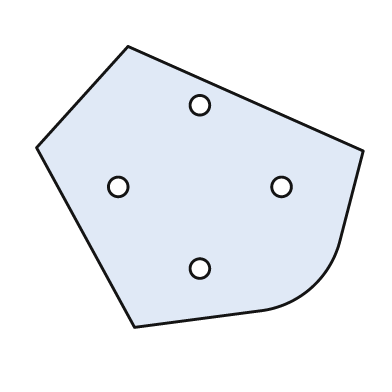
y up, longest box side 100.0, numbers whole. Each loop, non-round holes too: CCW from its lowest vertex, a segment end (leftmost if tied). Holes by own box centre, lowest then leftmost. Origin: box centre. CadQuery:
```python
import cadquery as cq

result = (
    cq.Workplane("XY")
    .moveTo(-20.0, -43.0)
    .lineTo(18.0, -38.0)
    .threePointArc((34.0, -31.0), (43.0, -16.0))
    .lineTo(50.0, 11.0)
    .lineTo(-22.0, 43.0)
    .lineTo(-50.0, 12.0)
    .close()
    .moveTo(0.0, -25.0)
    .circle(3.0)
    .moveTo(-25.0, 0.0)
    .circle(3.0)
    .moveTo(25.0, 0.0)
    .circle(3.0)
    .moveTo(0.0, 25.0)
    .circle(3.0)
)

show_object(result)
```